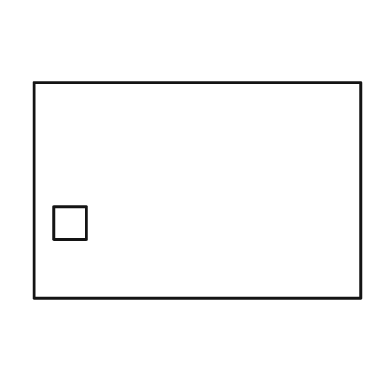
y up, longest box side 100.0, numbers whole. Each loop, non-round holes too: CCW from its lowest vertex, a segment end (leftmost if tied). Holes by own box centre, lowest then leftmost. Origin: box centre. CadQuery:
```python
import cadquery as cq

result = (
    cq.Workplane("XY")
    .moveTo(-50.0, -33.0)
    .lineTo(50.0, -33.0)
    .lineTo(50.0, 33.0)
    .lineTo(-50.0, 33.0)
    .close()
    .moveTo(-44.0, -15.0)
    .lineTo(-34.0, -15.0)
    .lineTo(-34.0, -5.0)
    .lineTo(-44.0, -5.0)
    .close()
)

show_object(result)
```